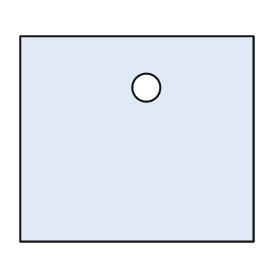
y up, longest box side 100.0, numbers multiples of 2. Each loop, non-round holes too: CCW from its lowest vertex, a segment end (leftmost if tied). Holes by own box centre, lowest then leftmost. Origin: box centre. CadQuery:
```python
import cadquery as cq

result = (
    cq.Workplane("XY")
    .moveTo(-50.0, -44.0)
    .lineTo(50.0, -44.0)
    .lineTo(50.0, 44.0)
    .lineTo(-50.0, 44.0)
    .close()
    .moveTo(4.0, 22.0)
    .circle(6.0)
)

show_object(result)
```